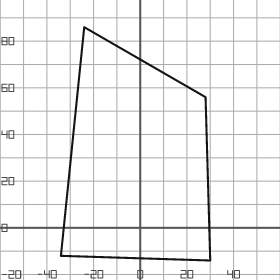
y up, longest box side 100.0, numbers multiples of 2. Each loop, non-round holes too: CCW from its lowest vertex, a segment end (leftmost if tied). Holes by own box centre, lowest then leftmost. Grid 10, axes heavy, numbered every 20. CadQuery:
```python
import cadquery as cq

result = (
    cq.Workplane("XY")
    .moveTo(30.0, -14.0)
    .lineTo(28.0, 56.0)
    .lineTo(-24.0, 86.0)
    .lineTo(-34.0, -12.0)
    .close()
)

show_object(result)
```